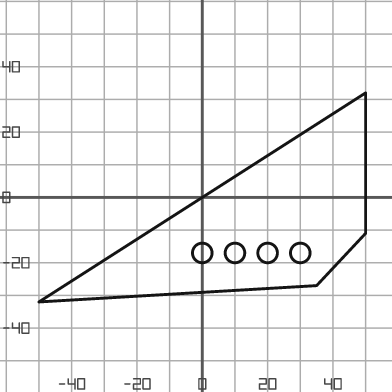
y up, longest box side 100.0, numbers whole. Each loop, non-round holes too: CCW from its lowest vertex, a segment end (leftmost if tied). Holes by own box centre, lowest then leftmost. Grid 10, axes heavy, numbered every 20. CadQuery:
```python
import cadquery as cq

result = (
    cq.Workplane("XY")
    .moveTo(-50.0, -32.0)
    .lineTo(35.0, -27.0)
    .lineTo(50.0, -11.0)
    .lineTo(50.0, 32.0)
    .close()
    .moveTo(0.0, -17.0)
    .circle(3.0)
    .moveTo(10.0, -17.0)
    .circle(3.0)
    .moveTo(20.0, -17.0)
    .circle(3.0)
    .moveTo(30.0, -17.0)
    .circle(3.0)
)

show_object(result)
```